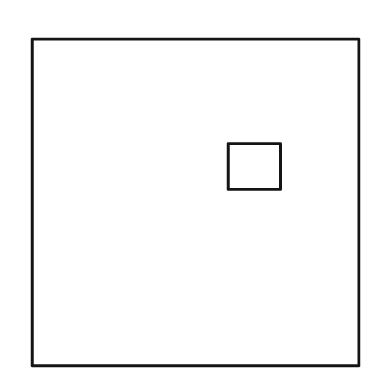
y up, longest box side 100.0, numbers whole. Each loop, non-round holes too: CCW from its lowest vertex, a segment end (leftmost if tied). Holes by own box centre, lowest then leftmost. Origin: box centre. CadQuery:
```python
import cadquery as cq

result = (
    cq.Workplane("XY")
    .moveTo(-50.0, -50.0)
    .lineTo(50.0, -50.0)
    .lineTo(50.0, 50.0)
    .lineTo(-50.0, 50.0)
    .close()
    .moveTo(10.0, 4.0)
    .lineTo(26.0, 4.0)
    .lineTo(26.0, 18.0)
    .lineTo(10.0, 18.0)
    .close()
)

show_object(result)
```